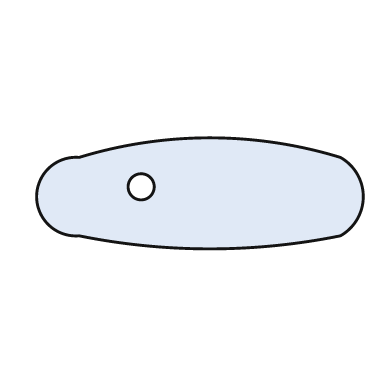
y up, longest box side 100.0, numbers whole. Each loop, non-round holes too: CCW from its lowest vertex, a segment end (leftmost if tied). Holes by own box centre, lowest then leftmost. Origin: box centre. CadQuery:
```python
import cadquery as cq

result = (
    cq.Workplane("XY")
    .moveTo(-37.0, -13.0)
    .threePointArc((3.0, -17.0), (43.0, -13.0))
    .threePointArc((50.0, -1.0), (43.0, 11.0))
    .threePointArc((3.0, 17.0), (-37.0, 11.0))
    .threePointArc((-50.0, -1.0), (-37.0, -13.0))
    .close()
    .moveTo(-18.0, 2.0)
    .circle(4.0)
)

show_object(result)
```